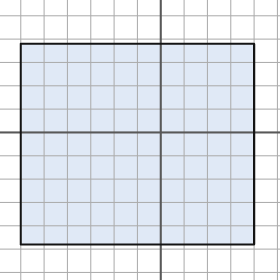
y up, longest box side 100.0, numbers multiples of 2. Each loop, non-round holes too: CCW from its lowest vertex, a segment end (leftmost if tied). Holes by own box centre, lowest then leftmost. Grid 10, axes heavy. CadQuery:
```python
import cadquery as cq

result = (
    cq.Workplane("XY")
    .moveTo(-60.0, -48.0)
    .lineTo(40.0, -48.0)
    .lineTo(40.0, 38.0)
    .lineTo(-60.0, 38.0)
    .close()
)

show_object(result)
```